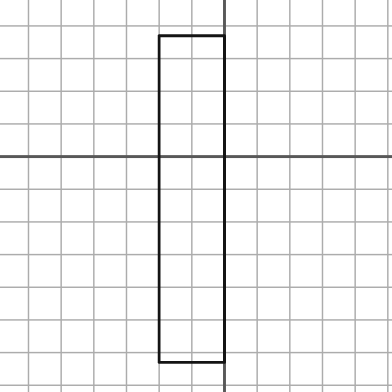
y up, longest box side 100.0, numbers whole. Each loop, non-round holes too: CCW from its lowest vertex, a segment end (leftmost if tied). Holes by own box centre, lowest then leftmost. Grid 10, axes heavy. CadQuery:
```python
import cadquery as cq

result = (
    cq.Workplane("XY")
    .moveTo(-20.0, -63.0)
    .lineTo(0.0, -63.0)
    .lineTo(0.0, 37.0)
    .lineTo(-20.0, 37.0)
    .close()
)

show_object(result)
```